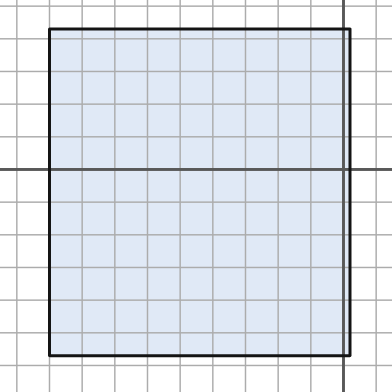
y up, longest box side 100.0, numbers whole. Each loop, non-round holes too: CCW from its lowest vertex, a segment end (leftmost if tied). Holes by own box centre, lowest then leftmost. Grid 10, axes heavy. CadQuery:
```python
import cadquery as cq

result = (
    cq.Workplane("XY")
    .moveTo(-90.0, -57.0)
    .lineTo(2.0, -57.0)
    .lineTo(2.0, 43.0)
    .lineTo(-90.0, 43.0)
    .close()
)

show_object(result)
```